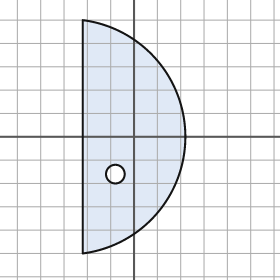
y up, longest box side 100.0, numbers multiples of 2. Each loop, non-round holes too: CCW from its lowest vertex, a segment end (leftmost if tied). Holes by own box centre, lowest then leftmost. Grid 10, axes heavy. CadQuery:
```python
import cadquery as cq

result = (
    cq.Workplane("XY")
    .moveTo(-22.0, -50.0)
    .threePointArc((22.0, 0.0), (-22.0, 50.0))
    .close()
    .moveTo(-8.0, -16.0)
    .circle(4.0)
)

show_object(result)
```